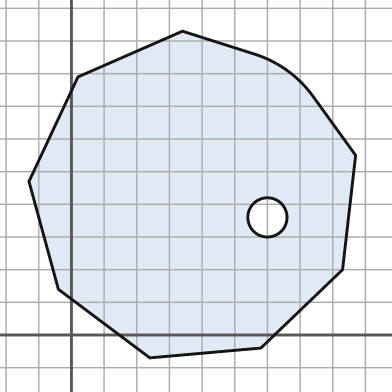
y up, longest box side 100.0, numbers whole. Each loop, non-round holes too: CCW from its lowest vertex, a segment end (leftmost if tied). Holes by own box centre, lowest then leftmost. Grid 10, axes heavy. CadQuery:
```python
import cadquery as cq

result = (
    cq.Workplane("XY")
    .moveTo(24.0, -7.0)
    .lineTo(58.0, -4.0)
    .lineTo(83.0, 20.0)
    .lineTo(87.0, 55.0)
    .lineTo(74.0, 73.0)
    .threePointArc((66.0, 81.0), (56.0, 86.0))
    .lineTo(34.0, 93.0)
    .lineTo(2.0, 79.0)
    .lineTo(-13.0, 47.0)
    .lineTo(-4.0, 14.0)
    .close()
    .moveTo(60.0, 36.0)
    .circle(6.0)
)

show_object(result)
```